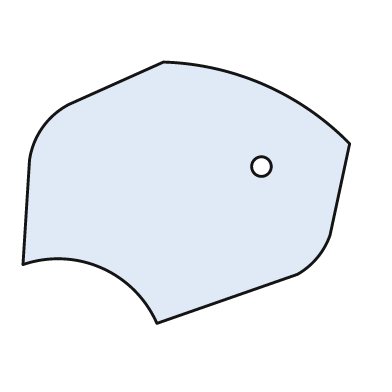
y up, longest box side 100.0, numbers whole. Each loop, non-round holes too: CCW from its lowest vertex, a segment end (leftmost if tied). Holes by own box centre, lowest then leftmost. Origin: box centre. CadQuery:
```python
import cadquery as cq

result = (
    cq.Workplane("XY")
    .moveTo(-9.0, -40.0)
    .lineTo(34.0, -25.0)
    .threePointArc((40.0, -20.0), (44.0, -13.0))
    .lineTo(50.0, 15.0)
    .threePointArc((24.0, 33.0), (-7.0, 40.0))
    .lineTo(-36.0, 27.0)
    .threePointArc((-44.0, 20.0), (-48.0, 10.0))
    .lineTo(-50.0, -22.0)
    .threePointArc((-26.0, -23.0), (-9.0, -40.0))
    .close()
    .moveTo(23.0, 8.0)
    .circle(3.0)
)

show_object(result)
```